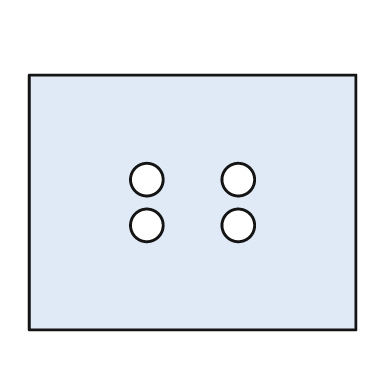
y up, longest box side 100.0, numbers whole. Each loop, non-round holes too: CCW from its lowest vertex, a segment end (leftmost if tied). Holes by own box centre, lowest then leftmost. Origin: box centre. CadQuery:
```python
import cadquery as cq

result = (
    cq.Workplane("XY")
    .moveTo(-50.0, -39.0)
    .lineTo(50.0, -39.0)
    .lineTo(50.0, 39.0)
    .lineTo(-50.0, 39.0)
    .close()
    .moveTo(-14.0, -7.0)
    .circle(5.0)
    .moveTo(14.0, -7.0)
    .circle(5.0)
    .moveTo(-14.0, 7.0)
    .circle(5.0)
    .moveTo(14.0, 7.0)
    .circle(5.0)
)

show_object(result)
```